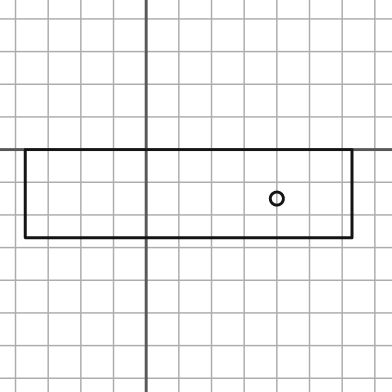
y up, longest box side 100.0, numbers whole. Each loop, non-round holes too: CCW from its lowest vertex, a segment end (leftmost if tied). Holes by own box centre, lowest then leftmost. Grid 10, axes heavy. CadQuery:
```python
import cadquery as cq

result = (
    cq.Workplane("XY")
    .moveTo(-37.0, -27.0)
    .lineTo(63.0, -27.0)
    .lineTo(63.0, 0.0)
    .lineTo(-37.0, 0.0)
    .close()
    .moveTo(40.0, -15.0)
    .circle(2.0)
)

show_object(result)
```